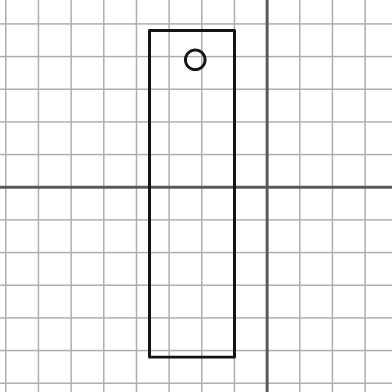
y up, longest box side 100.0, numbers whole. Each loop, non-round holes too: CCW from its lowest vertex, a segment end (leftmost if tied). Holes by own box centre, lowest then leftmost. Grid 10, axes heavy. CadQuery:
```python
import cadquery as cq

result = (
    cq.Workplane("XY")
    .moveTo(-36.0, -52.0)
    .lineTo(-10.0, -52.0)
    .lineTo(-10.0, 48.0)
    .lineTo(-36.0, 48.0)
    .close()
    .moveTo(-22.0, 39.0)
    .circle(3.0)
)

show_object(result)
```